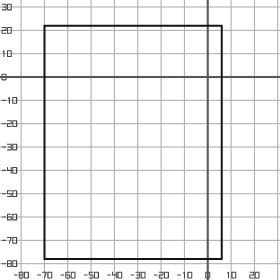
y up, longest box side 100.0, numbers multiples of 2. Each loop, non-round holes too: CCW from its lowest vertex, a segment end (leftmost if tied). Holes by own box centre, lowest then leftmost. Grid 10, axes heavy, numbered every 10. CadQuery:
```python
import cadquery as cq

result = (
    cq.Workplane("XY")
    .moveTo(-70.0, -78.0)
    .lineTo(6.0, -78.0)
    .lineTo(6.0, 22.0)
    .lineTo(-70.0, 22.0)
    .close()
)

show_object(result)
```